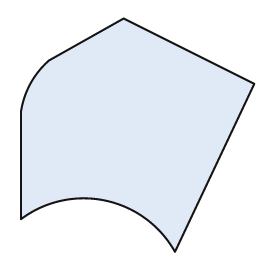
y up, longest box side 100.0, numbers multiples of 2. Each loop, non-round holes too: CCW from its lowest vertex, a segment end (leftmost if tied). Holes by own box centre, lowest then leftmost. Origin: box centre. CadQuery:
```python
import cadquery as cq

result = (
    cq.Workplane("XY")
    .moveTo(16.0, -50.0)
    .lineTo(50.0, 22.0)
    .lineTo(-6.0, 50.0)
    .lineTo(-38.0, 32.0)
    .threePointArc((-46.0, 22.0), (-50.0, 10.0))
    .lineTo(-50.0, -36.0)
    .threePointArc((-14.0, -28.0), (16.0, -50.0))
    .close()
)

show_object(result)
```